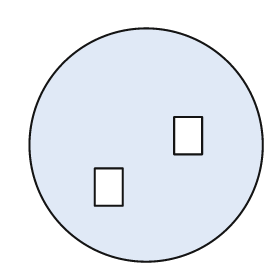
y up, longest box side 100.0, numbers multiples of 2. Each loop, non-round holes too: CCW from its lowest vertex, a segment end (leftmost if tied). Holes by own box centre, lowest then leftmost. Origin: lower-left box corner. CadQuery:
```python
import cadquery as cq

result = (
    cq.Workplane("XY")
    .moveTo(50.0, 50.0)
    .circle(50.0)
    .moveTo(28.0, 24.0)
    .lineTo(40.0, 24.0)
    .lineTo(40.0, 40.0)
    .lineTo(28.0, 40.0)
    .close()
    .moveTo(62.0, 46.0)
    .lineTo(74.0, 46.0)
    .lineTo(74.0, 62.0)
    .lineTo(62.0, 62.0)
    .close()
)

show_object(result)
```